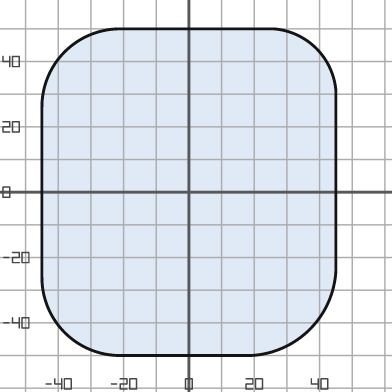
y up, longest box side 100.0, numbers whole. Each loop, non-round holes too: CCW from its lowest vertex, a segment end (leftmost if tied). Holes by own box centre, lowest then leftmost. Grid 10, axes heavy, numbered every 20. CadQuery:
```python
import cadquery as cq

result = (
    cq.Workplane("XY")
    .moveTo(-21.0, -50.0)
    .lineTo(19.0, -50.0)
    .threePointArc((37.0, -42.0), (45.0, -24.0))
    .lineTo(45.0, 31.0)
    .threePointArc((39.0, 44.0), (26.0, 50.0))
    .lineTo(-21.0, 50.0)
    .threePointArc((-38.0, 43.0), (-45.0, 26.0))
    .lineTo(-45.0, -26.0)
    .threePointArc((-38.0, -43.0), (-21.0, -50.0))
    .close()
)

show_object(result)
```